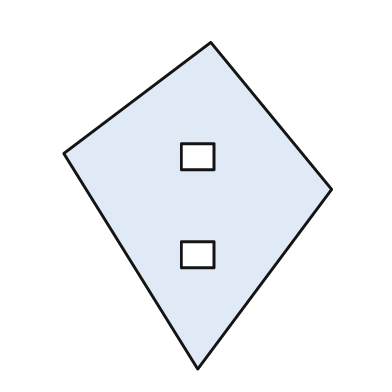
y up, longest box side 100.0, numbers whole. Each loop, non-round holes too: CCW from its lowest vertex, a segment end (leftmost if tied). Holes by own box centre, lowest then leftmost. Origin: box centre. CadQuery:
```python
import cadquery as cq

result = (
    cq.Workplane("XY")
    .moveTo(0.0, -50.0)
    .lineTo(41.0, 5.0)
    .lineTo(4.0, 50.0)
    .lineTo(-41.0, 16.0)
    .close()
    .moveTo(-5.0, -19.0)
    .lineTo(5.0, -19.0)
    .lineTo(5.0, -11.0)
    .lineTo(-5.0, -11.0)
    .close()
    .moveTo(-5.0, 11.0)
    .lineTo(5.0, 11.0)
    .lineTo(5.0, 19.0)
    .lineTo(-5.0, 19.0)
    .close()
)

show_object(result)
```